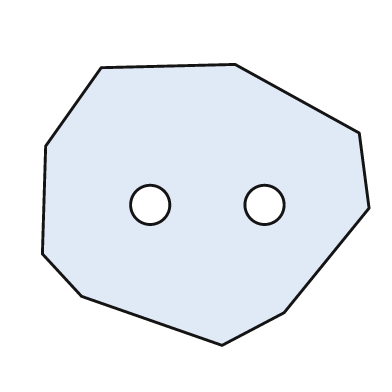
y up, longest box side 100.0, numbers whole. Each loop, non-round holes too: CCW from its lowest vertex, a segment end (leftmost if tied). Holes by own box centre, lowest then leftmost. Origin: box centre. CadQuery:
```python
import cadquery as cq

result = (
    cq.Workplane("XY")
    .moveTo(5.0, -43.0)
    .lineTo(24.0, -33.0)
    .lineTo(50.0, -1.0)
    .lineTo(47.0, 22.0)
    .lineTo(9.0, 43.0)
    .lineTo(-32.0, 42.0)
    .lineTo(-49.0, 18.0)
    .lineTo(-50.0, -15.0)
    .lineTo(-38.0, -28.0)
    .close()
    .moveTo(-17.0, 0.0)
    .circle(6.0)
    .moveTo(18.0, 0.0)
    .circle(6.0)
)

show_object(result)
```